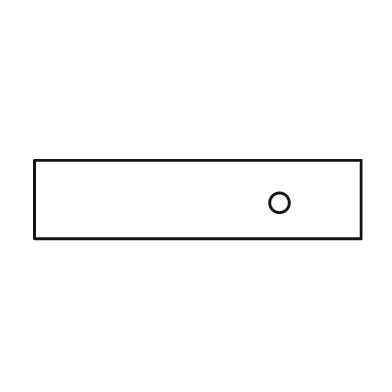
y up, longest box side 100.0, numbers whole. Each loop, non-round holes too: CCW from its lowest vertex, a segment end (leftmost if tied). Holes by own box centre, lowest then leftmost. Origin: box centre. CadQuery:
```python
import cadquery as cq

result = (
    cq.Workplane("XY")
    .moveTo(-50.0, -12.0)
    .lineTo(50.0, -12.0)
    .lineTo(50.0, 12.0)
    .lineTo(-50.0, 12.0)
    .close()
    .moveTo(25.0, -1.0)
    .circle(3.0)
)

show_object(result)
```